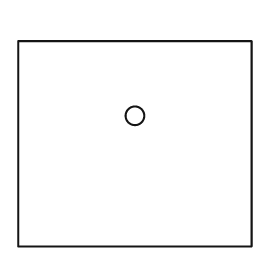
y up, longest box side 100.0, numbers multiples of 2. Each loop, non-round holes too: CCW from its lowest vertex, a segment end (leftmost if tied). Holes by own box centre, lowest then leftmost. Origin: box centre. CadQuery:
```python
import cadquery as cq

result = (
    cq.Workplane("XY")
    .moveTo(-50.0, -44.0)
    .lineTo(50.0, -44.0)
    .lineTo(50.0, 44.0)
    .lineTo(-50.0, 44.0)
    .close()
    .moveTo(0.0, 12.0)
    .circle(4.0)
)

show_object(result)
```